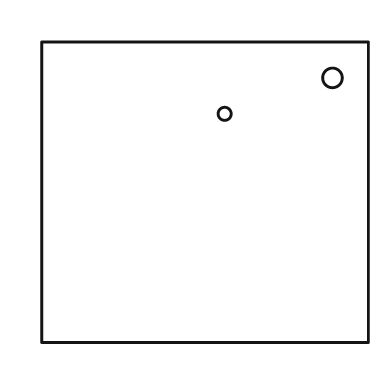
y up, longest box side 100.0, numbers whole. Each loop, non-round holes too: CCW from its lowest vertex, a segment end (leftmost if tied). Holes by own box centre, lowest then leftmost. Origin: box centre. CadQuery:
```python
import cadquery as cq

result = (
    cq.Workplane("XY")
    .moveTo(-50.0, -46.0)
    .lineTo(50.0, -46.0)
    .lineTo(50.0, 46.0)
    .lineTo(-50.0, 46.0)
    .close()
    .moveTo(6.0, 24.0)
    .circle(2.0)
    .moveTo(39.0, 35.0)
    .circle(3.0)
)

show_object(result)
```